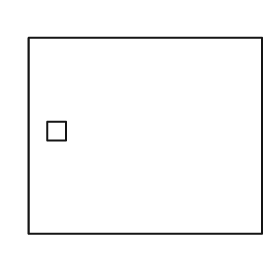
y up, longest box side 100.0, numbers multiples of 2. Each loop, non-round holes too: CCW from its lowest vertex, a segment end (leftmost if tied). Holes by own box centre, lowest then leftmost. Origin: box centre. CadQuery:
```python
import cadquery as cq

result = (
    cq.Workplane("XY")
    .moveTo(-50.0, -42.0)
    .lineTo(50.0, -42.0)
    .lineTo(50.0, 42.0)
    .lineTo(-50.0, 42.0)
    .close()
    .moveTo(-42.0, -2.0)
    .lineTo(-34.0, -2.0)
    .lineTo(-34.0, 6.0)
    .lineTo(-42.0, 6.0)
    .close()
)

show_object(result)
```